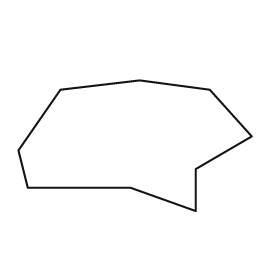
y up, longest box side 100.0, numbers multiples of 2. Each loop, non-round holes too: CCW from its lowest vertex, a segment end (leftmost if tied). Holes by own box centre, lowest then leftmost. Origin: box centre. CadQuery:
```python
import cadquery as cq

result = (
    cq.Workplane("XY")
    .moveTo(26.0, -28.0)
    .lineTo(26.0, -10.0)
    .lineTo(50.0, 4.0)
    .lineTo(32.0, 24.0)
    .lineTo(2.0, 28.0)
    .lineTo(-32.0, 24.0)
    .lineTo(-50.0, -2.0)
    .lineTo(-46.0, -18.0)
    .lineTo(-2.0, -18.0)
    .close()
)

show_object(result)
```